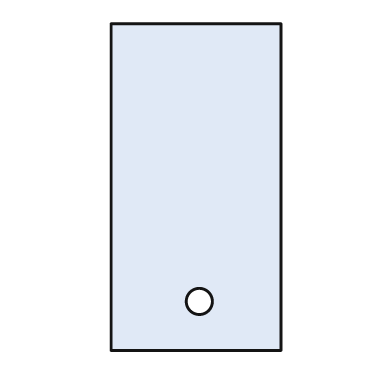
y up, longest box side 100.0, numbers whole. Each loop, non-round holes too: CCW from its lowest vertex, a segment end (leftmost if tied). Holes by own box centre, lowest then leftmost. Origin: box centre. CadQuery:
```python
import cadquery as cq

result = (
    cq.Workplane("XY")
    .moveTo(-26.0, -50.0)
    .lineTo(26.0, -50.0)
    .lineTo(26.0, 50.0)
    .lineTo(-26.0, 50.0)
    .close()
    .moveTo(1.0, -35.0)
    .circle(4.0)
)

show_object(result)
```